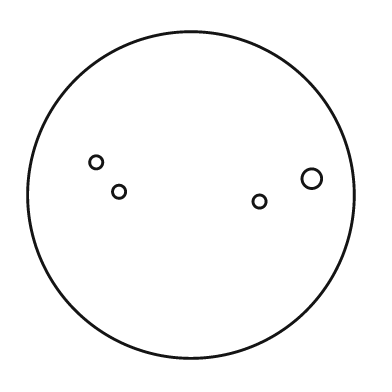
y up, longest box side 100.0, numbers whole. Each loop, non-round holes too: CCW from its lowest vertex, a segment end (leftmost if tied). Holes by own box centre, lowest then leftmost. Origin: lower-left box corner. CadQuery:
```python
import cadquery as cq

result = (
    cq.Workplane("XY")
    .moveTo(50.0, 50.0)
    .circle(50.0)
    .moveTo(71.0, 48.0)
    .circle(2.0)
    .moveTo(28.0, 51.0)
    .circle(2.0)
    .moveTo(87.0, 55.0)
    .circle(3.0)
    .moveTo(21.0, 60.0)
    .circle(2.0)
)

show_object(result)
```